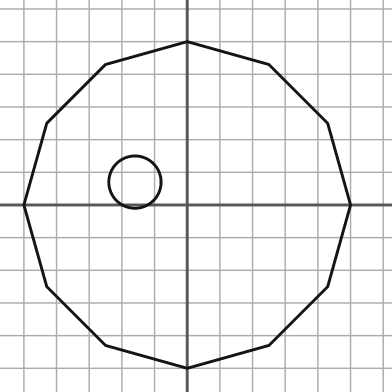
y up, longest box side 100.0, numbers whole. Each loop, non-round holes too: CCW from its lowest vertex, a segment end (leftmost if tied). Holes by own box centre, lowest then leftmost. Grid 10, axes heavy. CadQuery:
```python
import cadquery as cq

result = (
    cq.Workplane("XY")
    .moveTo(0.0, -50.0)
    .lineTo(25.0, -43.0)
    .lineTo(43.0, -25.0)
    .lineTo(50.0, 0.0)
    .lineTo(43.0, 25.0)
    .lineTo(25.0, 43.0)
    .lineTo(0.0, 50.0)
    .lineTo(-25.0, 43.0)
    .lineTo(-43.0, 25.0)
    .lineTo(-50.0, 0.0)
    .lineTo(-43.0, -25.0)
    .lineTo(-25.0, -43.0)
    .close()
    .moveTo(-16.0, 7.0)
    .circle(8.0)
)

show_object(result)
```